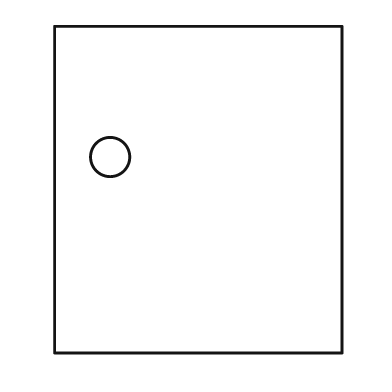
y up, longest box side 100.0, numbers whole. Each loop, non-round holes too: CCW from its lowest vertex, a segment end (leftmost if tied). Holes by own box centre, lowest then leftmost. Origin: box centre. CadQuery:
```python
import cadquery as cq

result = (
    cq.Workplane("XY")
    .moveTo(-44.0, -50.0)
    .lineTo(44.0, -50.0)
    .lineTo(44.0, 50.0)
    .lineTo(-44.0, 50.0)
    .close()
    .moveTo(-27.0, 10.0)
    .circle(6.0)
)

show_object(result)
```